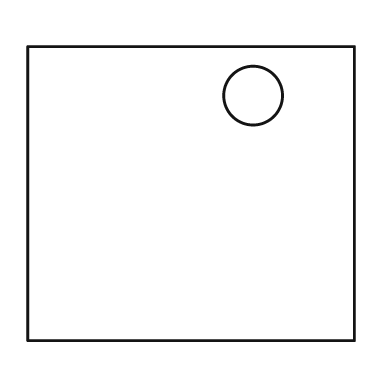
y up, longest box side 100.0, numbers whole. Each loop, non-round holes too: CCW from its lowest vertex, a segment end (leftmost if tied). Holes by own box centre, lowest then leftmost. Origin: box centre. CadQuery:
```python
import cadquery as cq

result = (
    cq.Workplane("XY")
    .moveTo(-50.0, -45.0)
    .lineTo(50.0, -45.0)
    .lineTo(50.0, 45.0)
    .lineTo(-50.0, 45.0)
    .close()
    .moveTo(19.0, 30.0)
    .circle(9.0)
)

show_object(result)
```